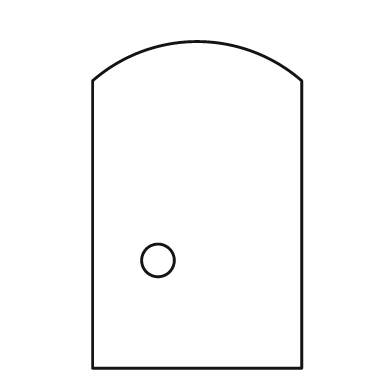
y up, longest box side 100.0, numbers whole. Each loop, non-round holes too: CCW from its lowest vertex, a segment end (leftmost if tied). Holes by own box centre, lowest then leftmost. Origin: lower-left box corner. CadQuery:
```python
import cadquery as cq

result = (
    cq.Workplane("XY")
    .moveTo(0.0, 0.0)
    .lineTo(64.0, 0.0)
    .lineTo(64.0, 88.0)
    .threePointArc((32.0, 100.0), (0.0, 88.0))
    .close()
    .moveTo(20.0, 33.0)
    .circle(5.0)
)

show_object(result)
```